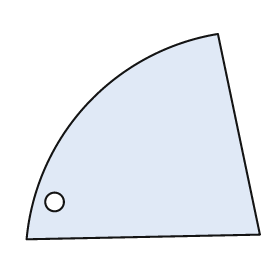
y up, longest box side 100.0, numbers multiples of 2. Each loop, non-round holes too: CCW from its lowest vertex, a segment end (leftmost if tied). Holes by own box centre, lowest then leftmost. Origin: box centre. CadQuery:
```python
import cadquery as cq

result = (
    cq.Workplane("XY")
    .moveTo(-50.0, -44.0)
    .lineTo(50.0, -42.0)
    .lineTo(32.0, 44.0)
    .threePointArc((-24.0, 14.0), (-50.0, -44.0))
    .close()
    .moveTo(-38.0, -28.0)
    .circle(4.0)
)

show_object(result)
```